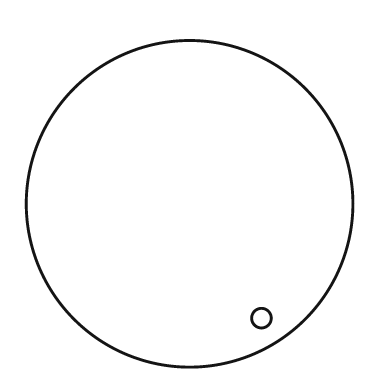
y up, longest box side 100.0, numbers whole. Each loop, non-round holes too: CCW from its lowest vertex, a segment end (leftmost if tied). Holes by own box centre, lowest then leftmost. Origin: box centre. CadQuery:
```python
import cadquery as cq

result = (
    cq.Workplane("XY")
    .moveTo(0.0, 0.0)
    .circle(50.0)
    .moveTo(22.0, -35.0)
    .circle(3.0)
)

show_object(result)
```